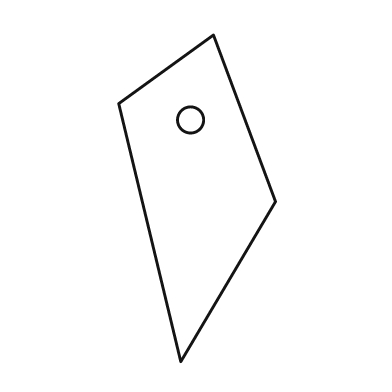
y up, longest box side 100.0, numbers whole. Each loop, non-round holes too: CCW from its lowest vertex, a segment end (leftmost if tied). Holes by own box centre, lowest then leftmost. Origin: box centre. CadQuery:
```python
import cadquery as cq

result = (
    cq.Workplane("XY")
    .moveTo(-5.0, -50.0)
    .lineTo(24.0, -1.0)
    .lineTo(5.0, 50.0)
    .lineTo(-24.0, 29.0)
    .close()
    .moveTo(-2.0, 24.0)
    .circle(4.0)
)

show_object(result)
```